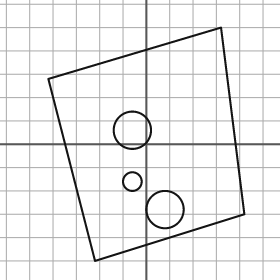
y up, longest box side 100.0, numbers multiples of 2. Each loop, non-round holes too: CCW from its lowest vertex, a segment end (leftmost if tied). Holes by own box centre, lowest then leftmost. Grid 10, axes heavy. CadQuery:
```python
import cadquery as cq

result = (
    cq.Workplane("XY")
    .moveTo(-22.0, -50.0)
    .lineTo(42.0, -30.0)
    .lineTo(32.0, 50.0)
    .lineTo(-42.0, 28.0)
    .close()
    .moveTo(8.0, -28.0)
    .circle(8.0)
    .moveTo(-6.0, -16.0)
    .circle(4.0)
    .moveTo(-6.0, 6.0)
    .circle(8.0)
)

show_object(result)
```